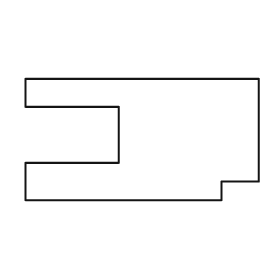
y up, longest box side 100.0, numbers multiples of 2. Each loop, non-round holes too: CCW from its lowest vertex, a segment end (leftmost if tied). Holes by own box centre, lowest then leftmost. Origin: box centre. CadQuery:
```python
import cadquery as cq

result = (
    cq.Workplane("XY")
    .moveTo(-50.0, -26.0)
    .lineTo(34.0, -26.0)
    .lineTo(34.0, -18.0)
    .lineTo(50.0, -18.0)
    .lineTo(50.0, 26.0)
    .lineTo(-50.0, 26.0)
    .lineTo(-50.0, 14.0)
    .lineTo(-10.0, 14.0)
    .lineTo(-10.0, -10.0)
    .lineTo(-50.0, -10.0)
    .close()
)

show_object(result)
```